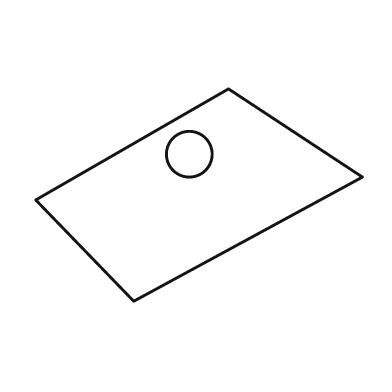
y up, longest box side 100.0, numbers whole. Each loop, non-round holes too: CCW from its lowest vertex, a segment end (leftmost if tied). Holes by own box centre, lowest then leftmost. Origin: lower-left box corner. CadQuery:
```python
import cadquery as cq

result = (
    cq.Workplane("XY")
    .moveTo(30.0, 0.0)
    .lineTo(100.0, 38.0)
    .lineTo(59.0, 65.0)
    .lineTo(0.0, 31.0)
    .close()
    .moveTo(47.0, 45.0)
    .circle(7.0)
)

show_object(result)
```